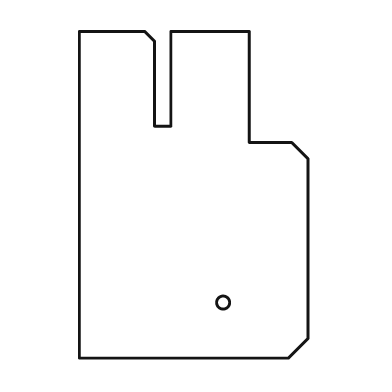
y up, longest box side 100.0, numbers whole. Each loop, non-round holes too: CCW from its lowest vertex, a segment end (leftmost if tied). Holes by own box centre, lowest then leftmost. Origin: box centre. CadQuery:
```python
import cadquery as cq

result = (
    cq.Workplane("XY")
    .moveTo(-35.0, -50.0)
    .lineTo(29.0, -50.0)
    .lineTo(35.0, -44.0)
    .lineTo(35.0, 11.0)
    .lineTo(30.0, 16.0)
    .lineTo(17.0, 16.0)
    .lineTo(17.0, 50.0)
    .lineTo(-7.0, 50.0)
    .lineTo(-7.0, 21.0)
    .lineTo(-12.0, 21.0)
    .lineTo(-12.0, 47.0)
    .lineTo(-15.0, 50.0)
    .lineTo(-35.0, 50.0)
    .close()
    .moveTo(9.0, -33.0)
    .circle(2.0)
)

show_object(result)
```